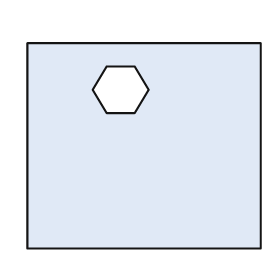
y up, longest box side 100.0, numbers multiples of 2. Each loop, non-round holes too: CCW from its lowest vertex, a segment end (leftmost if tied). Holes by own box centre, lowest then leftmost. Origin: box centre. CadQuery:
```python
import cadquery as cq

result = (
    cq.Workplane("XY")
    .moveTo(-50.0, -44.0)
    .lineTo(50.0, -44.0)
    .lineTo(50.0, 44.0)
    .lineTo(-50.0, 44.0)
    .close()
    .moveTo(-16.0, 14.0)
    .lineTo(-4.0, 14.0)
    .lineTo(2.0, 24.0)
    .lineTo(-4.0, 34.0)
    .lineTo(-16.0, 34.0)
    .lineTo(-22.0, 24.0)
    .close()
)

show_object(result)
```